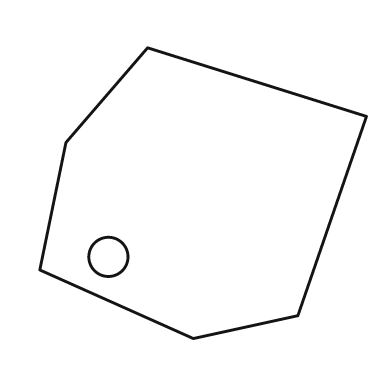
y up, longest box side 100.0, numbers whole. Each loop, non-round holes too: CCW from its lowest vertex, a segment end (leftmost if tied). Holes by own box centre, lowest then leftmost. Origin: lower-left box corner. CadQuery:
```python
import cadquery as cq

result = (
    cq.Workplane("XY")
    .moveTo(47.0, 0.0)
    .lineTo(79.0, 7.0)
    .lineTo(100.0, 68.0)
    .lineTo(33.0, 89.0)
    .lineTo(8.0, 60.0)
    .lineTo(0.0, 21.0)
    .close()
    .moveTo(21.0, 25.0)
    .circle(6.0)
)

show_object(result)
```